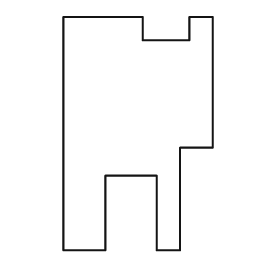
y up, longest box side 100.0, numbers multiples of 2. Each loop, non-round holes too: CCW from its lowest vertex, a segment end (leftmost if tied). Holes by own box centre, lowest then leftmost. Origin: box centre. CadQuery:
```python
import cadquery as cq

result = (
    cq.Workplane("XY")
    .moveTo(-32.0, -50.0)
    .lineTo(-14.0, -50.0)
    .lineTo(-14.0, -18.0)
    .lineTo(8.0, -18.0)
    .lineTo(8.0, -50.0)
    .lineTo(18.0, -50.0)
    .lineTo(18.0, -6.0)
    .lineTo(32.0, -6.0)
    .lineTo(32.0, 50.0)
    .lineTo(22.0, 50.0)
    .lineTo(22.0, 40.0)
    .lineTo(2.0, 40.0)
    .lineTo(2.0, 50.0)
    .lineTo(-32.0, 50.0)
    .close()
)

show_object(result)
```